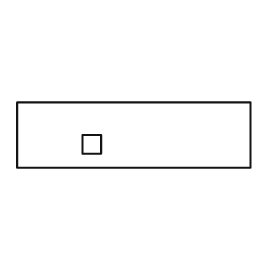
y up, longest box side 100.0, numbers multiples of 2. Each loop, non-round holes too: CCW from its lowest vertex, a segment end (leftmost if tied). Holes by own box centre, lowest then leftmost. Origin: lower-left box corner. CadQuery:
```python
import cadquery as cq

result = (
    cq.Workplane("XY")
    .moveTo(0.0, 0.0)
    .lineTo(100.0, 0.0)
    .lineTo(100.0, 28.0)
    .lineTo(0.0, 28.0)
    .close()
    .moveTo(28.0, 6.0)
    .lineTo(36.0, 6.0)
    .lineTo(36.0, 14.0)
    .lineTo(28.0, 14.0)
    .close()
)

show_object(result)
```